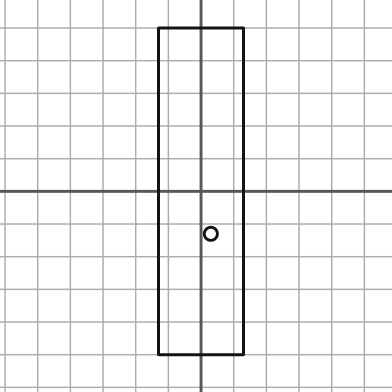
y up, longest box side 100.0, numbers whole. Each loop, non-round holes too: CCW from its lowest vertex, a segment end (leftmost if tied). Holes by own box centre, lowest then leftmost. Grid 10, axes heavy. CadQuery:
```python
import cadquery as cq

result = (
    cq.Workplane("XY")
    .moveTo(-13.0, -50.0)
    .lineTo(13.0, -50.0)
    .lineTo(13.0, 50.0)
    .lineTo(-13.0, 50.0)
    .close()
    .moveTo(3.0, -13.0)
    .circle(2.0)
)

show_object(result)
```